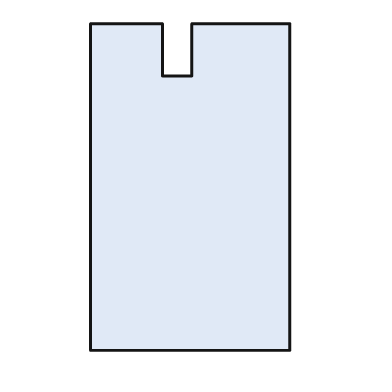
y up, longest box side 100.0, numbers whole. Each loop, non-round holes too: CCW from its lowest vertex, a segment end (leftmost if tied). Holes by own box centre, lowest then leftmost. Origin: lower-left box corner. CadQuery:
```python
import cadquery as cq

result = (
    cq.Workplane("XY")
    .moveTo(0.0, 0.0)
    .lineTo(61.0, 0.0)
    .lineTo(61.0, 100.0)
    .lineTo(31.0, 100.0)
    .lineTo(31.0, 84.0)
    .lineTo(22.0, 84.0)
    .lineTo(22.0, 100.0)
    .lineTo(0.0, 100.0)
    .close()
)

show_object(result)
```